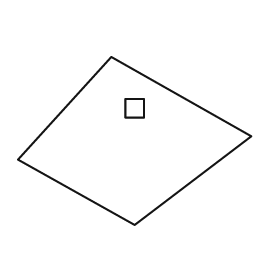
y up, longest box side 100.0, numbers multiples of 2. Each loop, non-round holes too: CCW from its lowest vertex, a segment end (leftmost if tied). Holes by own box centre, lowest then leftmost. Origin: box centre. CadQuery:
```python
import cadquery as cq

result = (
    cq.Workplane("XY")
    .moveTo(0.0, -36.0)
    .lineTo(50.0, 2.0)
    .lineTo(-10.0, 36.0)
    .lineTo(-50.0, -8.0)
    .close()
    .moveTo(-4.0, 10.0)
    .lineTo(4.0, 10.0)
    .lineTo(4.0, 18.0)
    .lineTo(-4.0, 18.0)
    .close()
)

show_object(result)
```